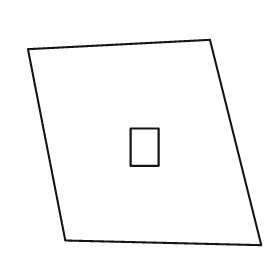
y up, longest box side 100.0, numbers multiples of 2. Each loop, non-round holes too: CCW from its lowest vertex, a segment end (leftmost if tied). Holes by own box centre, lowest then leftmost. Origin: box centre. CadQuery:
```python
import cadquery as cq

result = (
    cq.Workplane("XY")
    .moveTo(50.0, -44.0)
    .lineTo(28.0, 44.0)
    .lineTo(-50.0, 40.0)
    .lineTo(-34.0, -42.0)
    .close()
    .moveTo(-6.0, -10.0)
    .lineTo(6.0, -10.0)
    .lineTo(6.0, 6.0)
    .lineTo(-6.0, 6.0)
    .close()
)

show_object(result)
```